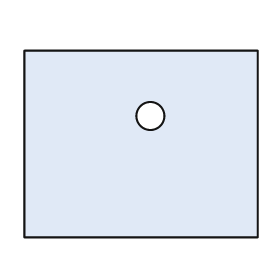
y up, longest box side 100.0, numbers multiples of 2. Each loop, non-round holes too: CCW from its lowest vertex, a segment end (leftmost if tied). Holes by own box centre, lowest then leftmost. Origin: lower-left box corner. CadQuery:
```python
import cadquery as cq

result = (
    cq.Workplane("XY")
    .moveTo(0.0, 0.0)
    .lineTo(100.0, 0.0)
    .lineTo(100.0, 80.0)
    .lineTo(0.0, 80.0)
    .close()
    .moveTo(54.0, 52.0)
    .circle(6.0)
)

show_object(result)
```